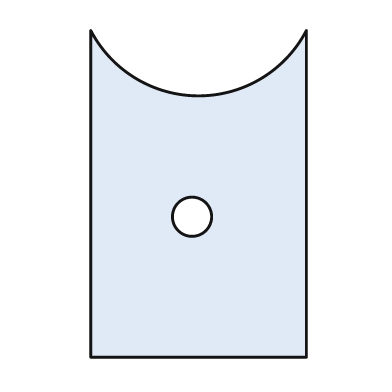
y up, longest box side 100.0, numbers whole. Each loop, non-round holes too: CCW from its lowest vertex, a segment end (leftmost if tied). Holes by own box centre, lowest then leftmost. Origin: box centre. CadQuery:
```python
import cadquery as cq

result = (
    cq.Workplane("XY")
    .moveTo(-33.0, -50.0)
    .lineTo(33.0, -50.0)
    .lineTo(33.0, 50.0)
    .threePointArc((0.0, 30.0), (-33.0, 50.0))
    .close()
    .moveTo(-2.0, -7.0)
    .circle(6.0)
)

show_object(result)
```